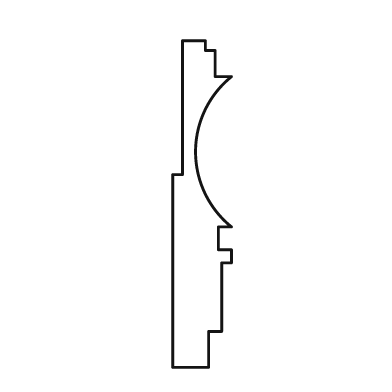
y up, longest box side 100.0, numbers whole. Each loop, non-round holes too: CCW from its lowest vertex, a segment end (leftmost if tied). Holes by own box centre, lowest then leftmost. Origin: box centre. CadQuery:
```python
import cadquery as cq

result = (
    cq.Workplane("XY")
    .moveTo(-9.0, -50.0)
    .lineTo(2.0, -50.0)
    .lineTo(2.0, -39.0)
    .lineTo(6.0, -39.0)
    .lineTo(6.0, -18.0)
    .lineTo(9.0, -18.0)
    .lineTo(9.0, -14.0)
    .lineTo(5.0, -14.0)
    .lineTo(5.0, -7.0)
    .lineTo(9.0, -7.0)
    .threePointArc((-2.0, 16.0), (9.0, 39.0))
    .lineTo(4.0, 39.0)
    .lineTo(4.0, 47.0)
    .lineTo(1.0, 47.0)
    .lineTo(1.0, 50.0)
    .lineTo(-6.0, 50.0)
    .lineTo(-6.0, 9.0)
    .lineTo(-9.0, 9.0)
    .close()
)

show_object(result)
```